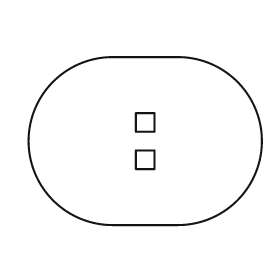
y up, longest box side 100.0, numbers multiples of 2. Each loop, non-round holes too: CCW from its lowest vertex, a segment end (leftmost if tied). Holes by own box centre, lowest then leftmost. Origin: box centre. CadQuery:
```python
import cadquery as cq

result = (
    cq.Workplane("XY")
    .moveTo(-14.0, -36.0)
    .lineTo(14.0, -36.0)
    .threePointArc((50.0, 0.0), (14.0, 36.0))
    .lineTo(-14.0, 36.0)
    .threePointArc((-50.0, 0.0), (-14.0, -36.0))
    .close()
    .moveTo(-4.0, -12.0)
    .lineTo(4.0, -12.0)
    .lineTo(4.0, -4.0)
    .lineTo(-4.0, -4.0)
    .close()
    .moveTo(-4.0, 4.0)
    .lineTo(4.0, 4.0)
    .lineTo(4.0, 12.0)
    .lineTo(-4.0, 12.0)
    .close()
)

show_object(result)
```